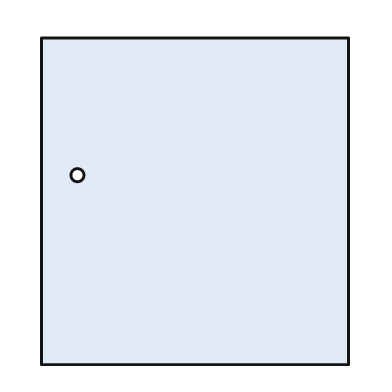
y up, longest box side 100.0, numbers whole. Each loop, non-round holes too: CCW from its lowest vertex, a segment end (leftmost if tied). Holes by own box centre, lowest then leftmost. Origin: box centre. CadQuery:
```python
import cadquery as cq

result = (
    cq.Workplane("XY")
    .moveTo(-47.0, -50.0)
    .lineTo(47.0, -50.0)
    .lineTo(47.0, 50.0)
    .lineTo(-47.0, 50.0)
    .close()
    .moveTo(-36.0, 8.0)
    .circle(2.0)
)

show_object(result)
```